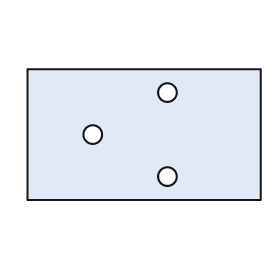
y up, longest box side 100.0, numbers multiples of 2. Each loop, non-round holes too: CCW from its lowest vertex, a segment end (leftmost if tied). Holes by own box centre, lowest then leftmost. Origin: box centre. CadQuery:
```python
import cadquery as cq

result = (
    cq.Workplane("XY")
    .moveTo(-50.0, -28.0)
    .lineTo(50.0, -28.0)
    .lineTo(50.0, 28.0)
    .lineTo(-50.0, 28.0)
    .close()
    .moveTo(10.0, -18.0)
    .circle(4.0)
    .moveTo(-22.0, 0.0)
    .circle(4.0)
    .moveTo(10.0, 18.0)
    .circle(4.0)
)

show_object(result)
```